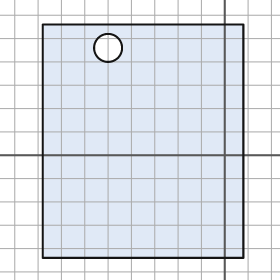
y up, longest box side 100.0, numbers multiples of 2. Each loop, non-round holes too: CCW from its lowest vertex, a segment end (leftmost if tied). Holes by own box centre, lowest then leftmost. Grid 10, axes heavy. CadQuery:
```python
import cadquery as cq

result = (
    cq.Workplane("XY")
    .moveTo(-78.0, -44.0)
    .lineTo(8.0, -44.0)
    .lineTo(8.0, 56.0)
    .lineTo(-78.0, 56.0)
    .close()
    .moveTo(-50.0, 46.0)
    .circle(6.0)
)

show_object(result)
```